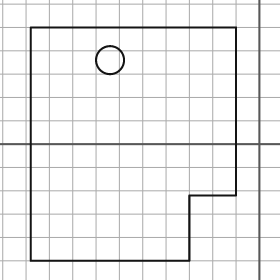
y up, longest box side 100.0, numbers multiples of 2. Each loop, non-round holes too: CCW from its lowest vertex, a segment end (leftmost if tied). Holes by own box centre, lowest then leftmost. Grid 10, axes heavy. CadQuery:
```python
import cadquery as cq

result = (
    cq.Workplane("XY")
    .moveTo(-98.0, -50.0)
    .lineTo(-30.0, -50.0)
    .lineTo(-30.0, -22.0)
    .lineTo(-10.0, -22.0)
    .lineTo(-10.0, 50.0)
    .lineTo(-98.0, 50.0)
    .close()
    .moveTo(-64.0, 36.0)
    .circle(6.0)
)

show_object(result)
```